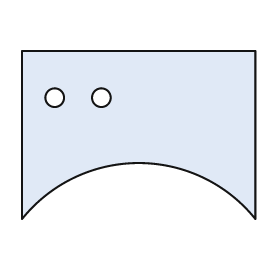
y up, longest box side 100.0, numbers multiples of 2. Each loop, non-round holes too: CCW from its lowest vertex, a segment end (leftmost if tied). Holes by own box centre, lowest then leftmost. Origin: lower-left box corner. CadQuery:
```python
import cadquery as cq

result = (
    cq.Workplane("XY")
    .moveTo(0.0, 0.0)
    .threePointArc((50.0, 24.0), (100.0, 0.0))
    .lineTo(100.0, 72.0)
    .lineTo(0.0, 72.0)
    .close()
    .moveTo(14.0, 52.0)
    .circle(4.0)
    .moveTo(34.0, 52.0)
    .circle(4.0)
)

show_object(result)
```